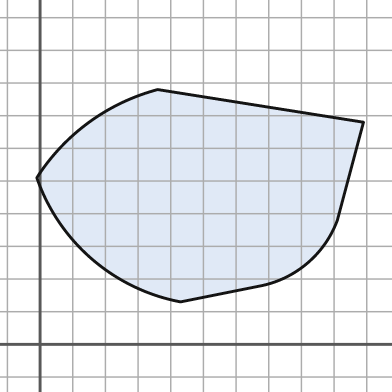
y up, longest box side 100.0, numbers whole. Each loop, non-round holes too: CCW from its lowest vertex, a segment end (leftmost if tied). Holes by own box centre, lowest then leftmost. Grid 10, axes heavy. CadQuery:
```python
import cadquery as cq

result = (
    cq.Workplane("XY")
    .moveTo(43.0, 13.0)
    .lineTo(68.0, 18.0)
    .threePointArc((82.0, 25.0), (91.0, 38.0))
    .lineTo(99.0, 68.0)
    .lineTo(36.0, 78.0)
    .threePointArc((15.0, 68.0), (-1.0, 51.0))
    .threePointArc((16.0, 26.0), (43.0, 13.0))
    .close()
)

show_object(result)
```